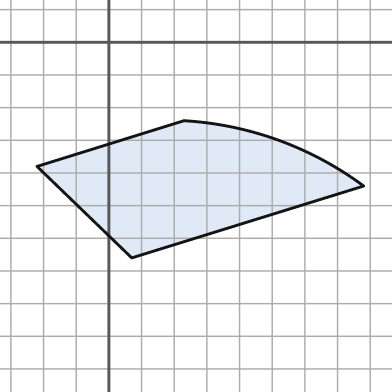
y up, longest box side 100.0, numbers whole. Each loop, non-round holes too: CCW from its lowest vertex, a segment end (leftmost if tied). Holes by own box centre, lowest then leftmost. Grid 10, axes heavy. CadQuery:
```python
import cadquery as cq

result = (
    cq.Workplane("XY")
    .moveTo(7.0, -66.0)
    .lineTo(78.0, -44.0)
    .threePointArc((52.0, -30.0), (23.0, -24.0))
    .lineTo(-22.0, -38.0)
    .close()
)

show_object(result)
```